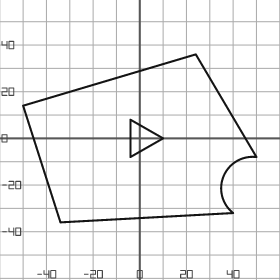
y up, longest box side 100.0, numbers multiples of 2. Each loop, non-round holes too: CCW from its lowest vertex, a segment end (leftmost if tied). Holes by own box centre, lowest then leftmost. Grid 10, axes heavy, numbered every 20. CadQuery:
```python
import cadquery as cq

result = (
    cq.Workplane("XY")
    .moveTo(-34.0, -36.0)
    .lineTo(40.0, -32.0)
    .threePointArc((36.0, -16.0), (50.0, -8.0))
    .lineTo(24.0, 36.0)
    .lineTo(-50.0, 14.0)
    .close()
    .moveTo(-4.0, -8.0)
    .lineTo(10.0, 0.0)
    .lineTo(-4.0, 8.0)
    .close()
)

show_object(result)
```